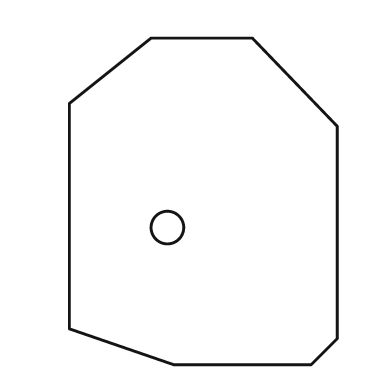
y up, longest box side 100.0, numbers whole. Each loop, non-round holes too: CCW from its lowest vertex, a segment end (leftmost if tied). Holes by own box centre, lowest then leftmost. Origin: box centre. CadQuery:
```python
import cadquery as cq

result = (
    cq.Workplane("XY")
    .moveTo(-9.0, -50.0)
    .lineTo(33.0, -50.0)
    .lineTo(41.0, -42.0)
    .lineTo(41.0, 23.0)
    .lineTo(15.0, 50.0)
    .lineTo(-16.0, 50.0)
    .lineTo(-41.0, 30.0)
    .lineTo(-41.0, -39.0)
    .close()
    .moveTo(-11.0, -8.0)
    .circle(5.0)
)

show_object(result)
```